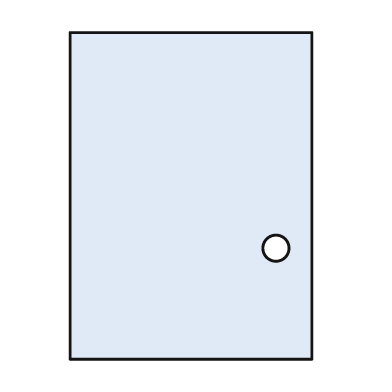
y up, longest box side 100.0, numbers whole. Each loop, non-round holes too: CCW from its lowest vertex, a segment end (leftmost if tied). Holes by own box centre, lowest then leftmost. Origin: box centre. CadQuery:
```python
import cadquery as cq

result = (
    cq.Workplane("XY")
    .moveTo(-37.0, -50.0)
    .lineTo(37.0, -50.0)
    .lineTo(37.0, 50.0)
    .lineTo(-37.0, 50.0)
    .close()
    .moveTo(26.0, -16.0)
    .circle(4.0)
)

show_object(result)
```